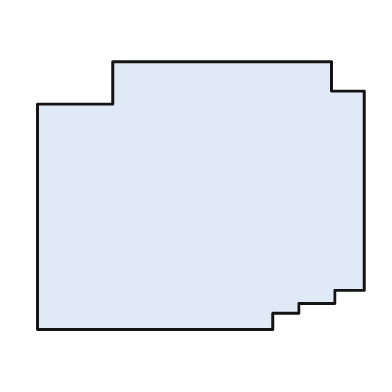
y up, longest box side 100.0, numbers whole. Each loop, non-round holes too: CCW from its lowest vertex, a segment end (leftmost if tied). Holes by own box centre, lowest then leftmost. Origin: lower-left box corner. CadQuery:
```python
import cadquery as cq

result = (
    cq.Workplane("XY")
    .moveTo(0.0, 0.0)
    .lineTo(72.0, 0.0)
    .lineTo(72.0, 5.0)
    .lineTo(80.0, 5.0)
    .lineTo(80.0, 8.0)
    .lineTo(91.0, 8.0)
    .lineTo(91.0, 12.0)
    .lineTo(100.0, 12.0)
    .lineTo(100.0, 73.0)
    .lineTo(90.0, 73.0)
    .lineTo(90.0, 82.0)
    .lineTo(23.0, 82.0)
    .lineTo(23.0, 69.0)
    .lineTo(0.0, 69.0)
    .close()
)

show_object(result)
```